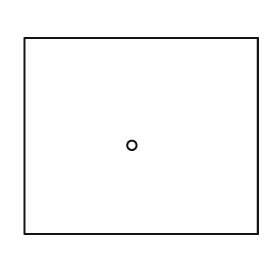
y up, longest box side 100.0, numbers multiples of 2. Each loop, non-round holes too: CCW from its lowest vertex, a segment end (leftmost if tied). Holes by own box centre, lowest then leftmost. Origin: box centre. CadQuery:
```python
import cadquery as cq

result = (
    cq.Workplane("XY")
    .moveTo(-50.0, -42.0)
    .lineTo(50.0, -42.0)
    .lineTo(50.0, 42.0)
    .lineTo(-50.0, 42.0)
    .close()
    .moveTo(-4.0, -4.0)
    .circle(2.0)
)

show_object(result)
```